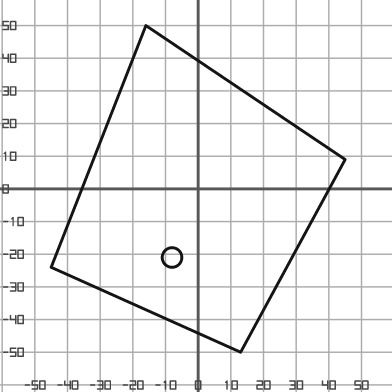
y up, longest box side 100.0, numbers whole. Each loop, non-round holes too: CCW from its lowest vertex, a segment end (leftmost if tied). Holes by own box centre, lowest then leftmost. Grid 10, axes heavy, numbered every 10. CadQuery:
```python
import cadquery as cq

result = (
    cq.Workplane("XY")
    .moveTo(13.0, -50.0)
    .lineTo(45.0, 9.0)
    .lineTo(-16.0, 50.0)
    .lineTo(-45.0, -24.0)
    .close()
    .moveTo(-8.0, -21.0)
    .circle(3.0)
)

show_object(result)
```